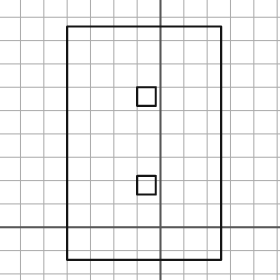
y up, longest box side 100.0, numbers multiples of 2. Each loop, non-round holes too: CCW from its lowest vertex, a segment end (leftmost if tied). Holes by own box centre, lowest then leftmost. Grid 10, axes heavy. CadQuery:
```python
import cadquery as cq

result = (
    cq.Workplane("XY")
    .moveTo(-40.0, -14.0)
    .lineTo(26.0, -14.0)
    .lineTo(26.0, 86.0)
    .lineTo(-40.0, 86.0)
    .close()
    .moveTo(-10.0, 14.0)
    .lineTo(-2.0, 14.0)
    .lineTo(-2.0, 22.0)
    .lineTo(-10.0, 22.0)
    .close()
    .moveTo(-10.0, 52.0)
    .lineTo(-2.0, 52.0)
    .lineTo(-2.0, 60.0)
    .lineTo(-10.0, 60.0)
    .close()
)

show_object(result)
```